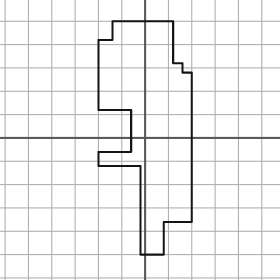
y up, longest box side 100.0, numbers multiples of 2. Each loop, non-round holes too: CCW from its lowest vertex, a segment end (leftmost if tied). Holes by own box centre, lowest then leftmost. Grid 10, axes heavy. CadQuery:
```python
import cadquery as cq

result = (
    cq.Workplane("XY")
    .moveTo(-2.0, -50.0)
    .lineTo(8.0, -50.0)
    .lineTo(8.0, -36.0)
    .lineTo(20.0, -36.0)
    .lineTo(20.0, 28.0)
    .lineTo(16.0, 28.0)
    .lineTo(16.0, 32.0)
    .lineTo(12.0, 32.0)
    .lineTo(12.0, 50.0)
    .lineTo(-14.0, 50.0)
    .lineTo(-14.0, 42.0)
    .lineTo(-20.0, 42.0)
    .lineTo(-20.0, 12.0)
    .lineTo(-6.0, 12.0)
    .lineTo(-6.0, -6.0)
    .lineTo(-20.0, -6.0)
    .lineTo(-20.0, -12.0)
    .lineTo(-2.0, -12.0)
    .close()
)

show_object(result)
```